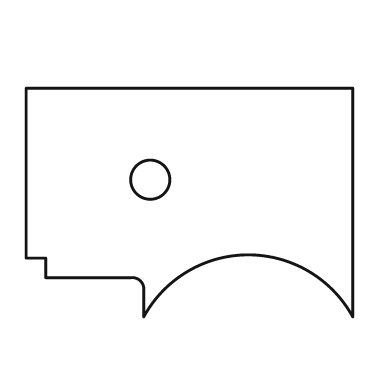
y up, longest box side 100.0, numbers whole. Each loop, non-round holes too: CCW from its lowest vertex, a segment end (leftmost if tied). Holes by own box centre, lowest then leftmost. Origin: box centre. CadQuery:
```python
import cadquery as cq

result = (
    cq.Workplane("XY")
    .moveTo(-14.0, -35.0)
    .threePointArc((18.0, -16.0), (50.0, -35.0))
    .lineTo(50.0, 35.0)
    .lineTo(-50.0, 35.0)
    .lineTo(-50.0, -17.0)
    .lineTo(-44.0, -17.0)
    .lineTo(-44.0, -23.0)
    .lineTo(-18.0, -23.0)
    .threePointArc((-15.0, -24.0), (-14.0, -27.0))
    .close()
    .moveTo(-12.0, 7.0)
    .circle(6.0)
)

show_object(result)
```